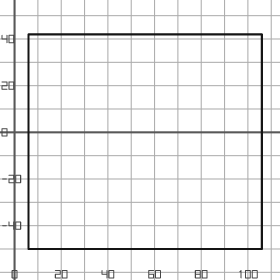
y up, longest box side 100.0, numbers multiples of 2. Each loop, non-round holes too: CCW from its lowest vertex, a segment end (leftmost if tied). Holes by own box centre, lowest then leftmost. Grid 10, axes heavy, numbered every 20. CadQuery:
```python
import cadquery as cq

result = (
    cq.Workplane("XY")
    .moveTo(6.0, -50.0)
    .lineTo(106.0, -50.0)
    .lineTo(106.0, 42.0)
    .lineTo(6.0, 42.0)
    .close()
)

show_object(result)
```